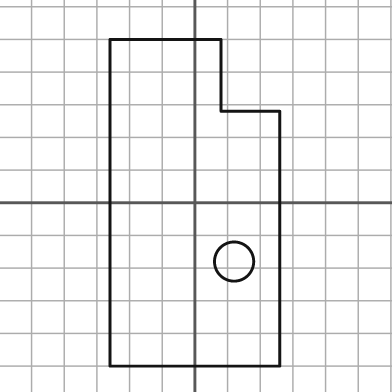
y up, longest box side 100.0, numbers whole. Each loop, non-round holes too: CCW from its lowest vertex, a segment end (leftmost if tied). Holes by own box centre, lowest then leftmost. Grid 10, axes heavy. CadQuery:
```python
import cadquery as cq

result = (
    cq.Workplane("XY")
    .moveTo(-26.0, -50.0)
    .lineTo(26.0, -50.0)
    .lineTo(26.0, 28.0)
    .lineTo(8.0, 28.0)
    .lineTo(8.0, 50.0)
    .lineTo(-26.0, 50.0)
    .close()
    .moveTo(12.0, -18.0)
    .circle(6.0)
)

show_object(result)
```